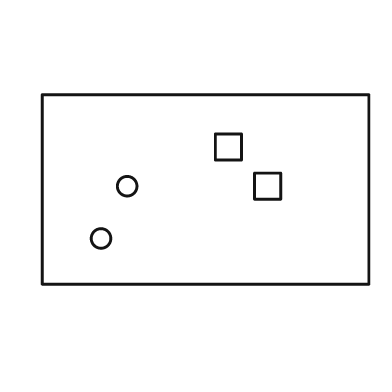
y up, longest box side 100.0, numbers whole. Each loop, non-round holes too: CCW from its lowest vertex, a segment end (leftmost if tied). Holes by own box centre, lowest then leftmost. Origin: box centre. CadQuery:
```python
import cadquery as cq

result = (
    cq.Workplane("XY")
    .moveTo(-50.0, -29.0)
    .lineTo(50.0, -29.0)
    .lineTo(50.0, 29.0)
    .lineTo(-50.0, 29.0)
    .close()
    .moveTo(-32.0, -15.0)
    .circle(3.0)
    .moveTo(-24.0, 1.0)
    .circle(3.0)
    .moveTo(15.0, -3.0)
    .lineTo(23.0, -3.0)
    .lineTo(23.0, 5.0)
    .lineTo(15.0, 5.0)
    .close()
    .moveTo(3.0, 9.0)
    .lineTo(11.0, 9.0)
    .lineTo(11.0, 17.0)
    .lineTo(3.0, 17.0)
    .close()
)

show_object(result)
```